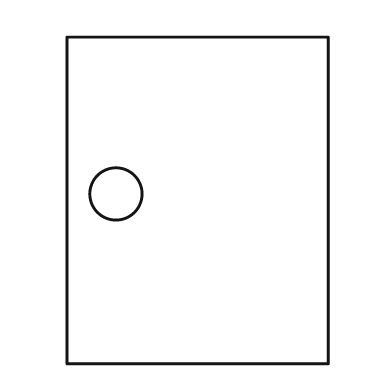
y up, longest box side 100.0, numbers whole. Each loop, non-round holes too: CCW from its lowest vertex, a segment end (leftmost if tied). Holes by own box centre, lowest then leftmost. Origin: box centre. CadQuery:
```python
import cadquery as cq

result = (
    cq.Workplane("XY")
    .moveTo(-40.0, -50.0)
    .lineTo(40.0, -50.0)
    .lineTo(40.0, 50.0)
    .lineTo(-40.0, 50.0)
    .close()
    .moveTo(-25.0, 2.0)
    .circle(8.0)
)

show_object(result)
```